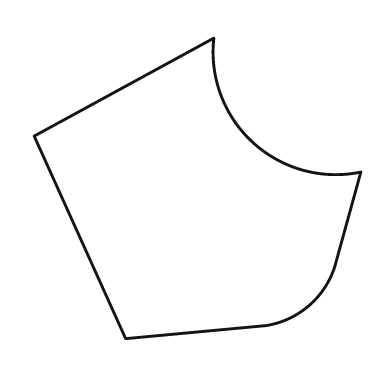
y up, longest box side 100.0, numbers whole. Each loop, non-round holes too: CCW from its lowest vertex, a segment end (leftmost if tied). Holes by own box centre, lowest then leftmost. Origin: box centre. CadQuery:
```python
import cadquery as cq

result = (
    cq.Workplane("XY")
    .moveTo(-22.0, -46.0)
    .lineTo(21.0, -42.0)
    .threePointArc((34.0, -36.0), (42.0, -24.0))
    .lineTo(50.0, 5.0)
    .threePointArc((17.0, 14.0), (5.0, 46.0))
    .lineTo(-50.0, 16.0)
    .close()
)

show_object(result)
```